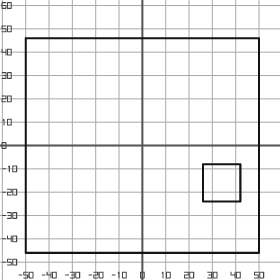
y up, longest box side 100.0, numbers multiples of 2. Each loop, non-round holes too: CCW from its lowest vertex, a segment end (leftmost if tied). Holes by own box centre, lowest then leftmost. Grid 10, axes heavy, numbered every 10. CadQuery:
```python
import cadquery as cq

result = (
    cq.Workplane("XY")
    .moveTo(-50.0, -46.0)
    .lineTo(50.0, -46.0)
    .lineTo(50.0, 46.0)
    .lineTo(-50.0, 46.0)
    .close()
    .moveTo(26.0, -24.0)
    .lineTo(42.0, -24.0)
    .lineTo(42.0, -8.0)
    .lineTo(26.0, -8.0)
    .close()
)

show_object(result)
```